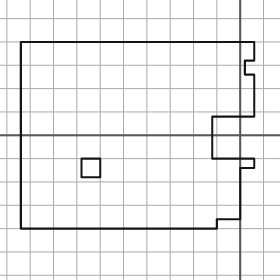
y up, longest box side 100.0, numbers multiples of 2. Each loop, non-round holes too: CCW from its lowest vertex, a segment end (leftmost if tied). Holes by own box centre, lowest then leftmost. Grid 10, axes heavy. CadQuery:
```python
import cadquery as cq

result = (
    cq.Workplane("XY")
    .moveTo(-94.0, -40.0)
    .lineTo(-10.0, -40.0)
    .lineTo(-10.0, -36.0)
    .lineTo(0.0, -36.0)
    .lineTo(0.0, -14.0)
    .lineTo(6.0, -14.0)
    .lineTo(6.0, -10.0)
    .lineTo(-12.0, -10.0)
    .lineTo(-12.0, 8.0)
    .lineTo(6.0, 8.0)
    .lineTo(6.0, 26.0)
    .lineTo(2.0, 26.0)
    .lineTo(2.0, 32.0)
    .lineTo(6.0, 32.0)
    .lineTo(6.0, 40.0)
    .lineTo(-94.0, 40.0)
    .close()
    .moveTo(-68.0, -18.0)
    .lineTo(-60.0, -18.0)
    .lineTo(-60.0, -10.0)
    .lineTo(-68.0, -10.0)
    .close()
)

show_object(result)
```